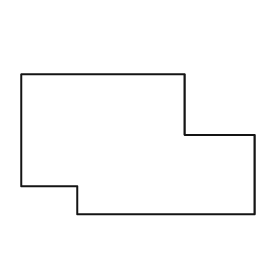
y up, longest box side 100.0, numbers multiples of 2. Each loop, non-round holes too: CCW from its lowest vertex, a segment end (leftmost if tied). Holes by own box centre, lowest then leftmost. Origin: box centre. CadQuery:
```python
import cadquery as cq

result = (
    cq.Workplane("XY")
    .moveTo(-26.0, -30.0)
    .lineTo(50.0, -30.0)
    .lineTo(50.0, 4.0)
    .lineTo(20.0, 4.0)
    .lineTo(20.0, 30.0)
    .lineTo(-50.0, 30.0)
    .lineTo(-50.0, -18.0)
    .lineTo(-26.0, -18.0)
    .close()
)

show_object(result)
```